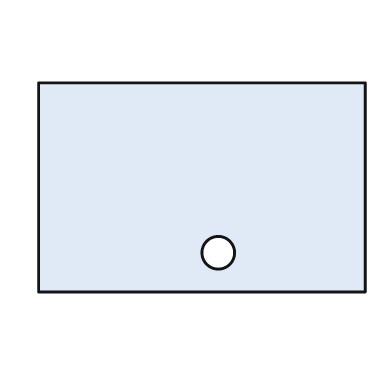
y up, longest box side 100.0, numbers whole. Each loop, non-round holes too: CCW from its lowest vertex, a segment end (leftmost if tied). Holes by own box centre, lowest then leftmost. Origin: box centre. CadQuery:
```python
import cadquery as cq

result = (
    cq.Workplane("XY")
    .moveTo(-50.0, -32.0)
    .lineTo(50.0, -32.0)
    .lineTo(50.0, 32.0)
    .lineTo(-50.0, 32.0)
    .close()
    .moveTo(5.0, -20.0)
    .circle(5.0)
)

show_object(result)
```